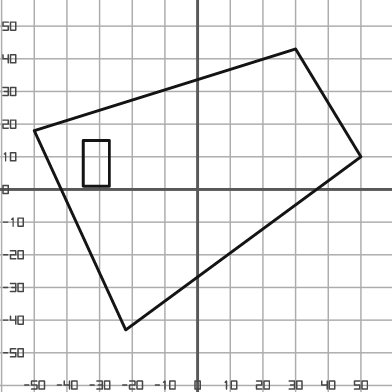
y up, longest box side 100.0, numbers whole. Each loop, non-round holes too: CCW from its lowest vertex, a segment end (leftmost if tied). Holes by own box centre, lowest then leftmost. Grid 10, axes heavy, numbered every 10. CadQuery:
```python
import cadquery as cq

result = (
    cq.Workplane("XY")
    .moveTo(-22.0, -43.0)
    .lineTo(50.0, 10.0)
    .lineTo(30.0, 43.0)
    .lineTo(-50.0, 18.0)
    .close()
    .moveTo(-35.0, 1.0)
    .lineTo(-27.0, 1.0)
    .lineTo(-27.0, 15.0)
    .lineTo(-35.0, 15.0)
    .close()
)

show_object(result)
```